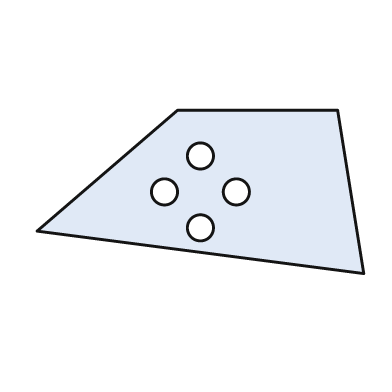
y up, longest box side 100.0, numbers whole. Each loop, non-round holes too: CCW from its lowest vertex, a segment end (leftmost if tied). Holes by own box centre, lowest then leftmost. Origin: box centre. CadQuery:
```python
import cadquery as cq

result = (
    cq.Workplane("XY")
    .moveTo(50.0, -25.0)
    .lineTo(42.0, 25.0)
    .lineTo(-7.0, 25.0)
    .lineTo(-50.0, -12.0)
    .close()
    .moveTo(0.0, -11.0)
    .circle(4.0)
    .moveTo(-11.0, 0.0)
    .circle(4.0)
    .moveTo(11.0, 0.0)
    .circle(4.0)
    .moveTo(0.0, 11.0)
    .circle(4.0)
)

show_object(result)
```